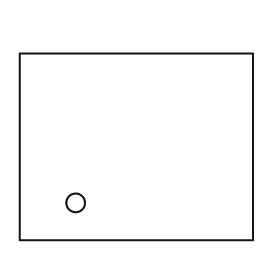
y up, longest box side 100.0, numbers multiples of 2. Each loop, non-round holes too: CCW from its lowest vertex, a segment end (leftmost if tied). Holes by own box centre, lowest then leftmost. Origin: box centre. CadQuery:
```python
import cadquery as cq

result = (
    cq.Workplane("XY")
    .moveTo(-50.0, -40.0)
    .lineTo(50.0, -40.0)
    .lineTo(50.0, 40.0)
    .lineTo(-50.0, 40.0)
    .close()
    .moveTo(-26.0, -24.0)
    .circle(4.0)
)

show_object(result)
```